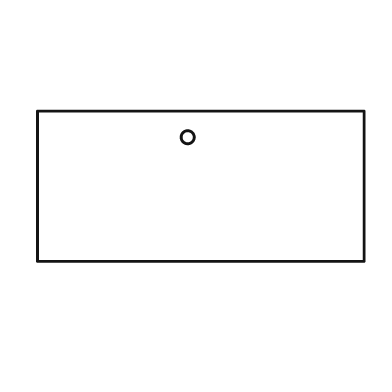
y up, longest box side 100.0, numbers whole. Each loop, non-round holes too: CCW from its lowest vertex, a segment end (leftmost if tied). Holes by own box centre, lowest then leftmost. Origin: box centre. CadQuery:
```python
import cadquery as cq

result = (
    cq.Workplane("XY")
    .moveTo(-50.0, -23.0)
    .lineTo(50.0, -23.0)
    .lineTo(50.0, 23.0)
    .lineTo(-50.0, 23.0)
    .close()
    .moveTo(-4.0, 15.0)
    .circle(2.0)
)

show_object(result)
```